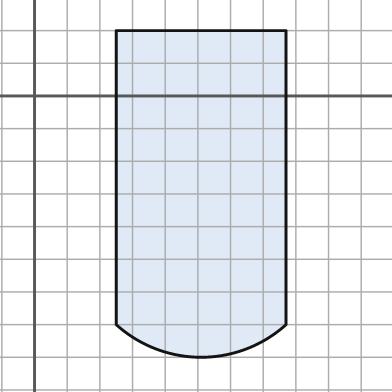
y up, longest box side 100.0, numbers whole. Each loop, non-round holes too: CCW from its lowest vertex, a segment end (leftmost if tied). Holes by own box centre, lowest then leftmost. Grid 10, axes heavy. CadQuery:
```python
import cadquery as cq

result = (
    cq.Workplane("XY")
    .moveTo(25.0, -70.0)
    .threePointArc((51.0, -80.0), (77.0, -70.0))
    .lineTo(77.0, 20.0)
    .lineTo(25.0, 20.0)
    .close()
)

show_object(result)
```